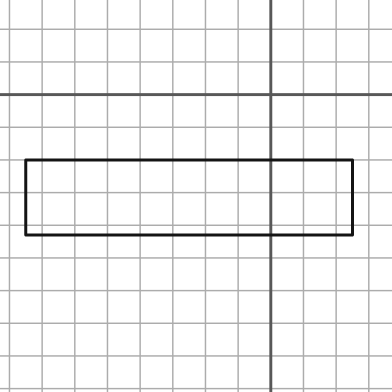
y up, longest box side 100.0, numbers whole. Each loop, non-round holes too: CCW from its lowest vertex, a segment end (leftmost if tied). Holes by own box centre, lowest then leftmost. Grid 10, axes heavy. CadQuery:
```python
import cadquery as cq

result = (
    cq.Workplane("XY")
    .moveTo(-75.0, -43.0)
    .lineTo(25.0, -43.0)
    .lineTo(25.0, -20.0)
    .lineTo(-75.0, -20.0)
    .close()
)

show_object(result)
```